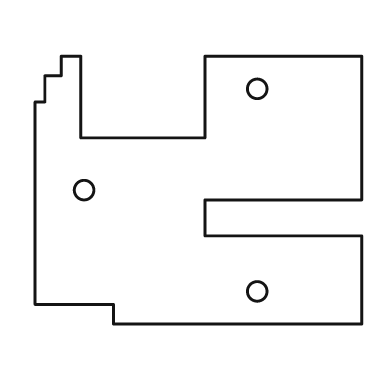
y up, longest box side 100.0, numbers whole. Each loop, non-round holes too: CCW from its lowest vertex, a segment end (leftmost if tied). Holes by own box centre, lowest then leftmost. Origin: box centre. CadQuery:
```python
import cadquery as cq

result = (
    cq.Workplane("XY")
    .moveTo(-26.0, -41.0)
    .lineTo(50.0, -41.0)
    .lineTo(50.0, -14.0)
    .lineTo(2.0, -14.0)
    .lineTo(2.0, -3.0)
    .lineTo(50.0, -3.0)
    .lineTo(50.0, 41.0)
    .lineTo(2.0, 41.0)
    .lineTo(2.0, 16.0)
    .lineTo(-36.0, 16.0)
    .lineTo(-36.0, 41.0)
    .lineTo(-42.0, 41.0)
    .lineTo(-42.0, 35.0)
    .lineTo(-47.0, 35.0)
    .lineTo(-47.0, 27.0)
    .lineTo(-50.0, 27.0)
    .lineTo(-50.0, -35.0)
    .lineTo(-26.0, -35.0)
    .close()
    .moveTo(18.0, -31.0)
    .circle(3.0)
    .moveTo(-35.0, 0.0)
    .circle(3.0)
    .moveTo(18.0, 31.0)
    .circle(3.0)
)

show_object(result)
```